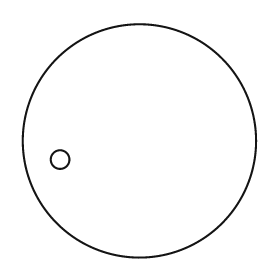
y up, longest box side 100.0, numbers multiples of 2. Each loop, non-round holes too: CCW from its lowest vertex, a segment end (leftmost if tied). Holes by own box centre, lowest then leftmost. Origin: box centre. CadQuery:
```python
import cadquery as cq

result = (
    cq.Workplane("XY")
    .moveTo(0.0, 0.0)
    .circle(50.0)
    .moveTo(-34.0, -8.0)
    .circle(4.0)
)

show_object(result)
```